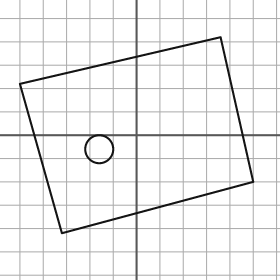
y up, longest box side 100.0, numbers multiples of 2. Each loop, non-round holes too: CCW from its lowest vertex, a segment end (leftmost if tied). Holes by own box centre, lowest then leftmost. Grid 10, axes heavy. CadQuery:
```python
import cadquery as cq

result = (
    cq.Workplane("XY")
    .moveTo(-32.0, -42.0)
    .lineTo(50.0, -20.0)
    .lineTo(36.0, 42.0)
    .lineTo(-50.0, 22.0)
    .close()
    .moveTo(-16.0, -6.0)
    .circle(6.0)
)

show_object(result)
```